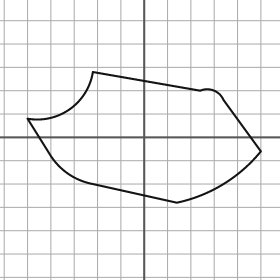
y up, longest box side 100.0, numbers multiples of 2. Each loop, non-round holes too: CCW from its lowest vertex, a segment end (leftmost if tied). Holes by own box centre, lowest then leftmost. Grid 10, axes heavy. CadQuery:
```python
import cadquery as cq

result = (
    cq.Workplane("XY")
    .moveTo(14.0, -28.0)
    .threePointArc((34.0, -20.0), (50.0, -6.0))
    .lineTo(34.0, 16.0)
    .threePointArc((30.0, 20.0), (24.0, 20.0))
    .lineTo(-22.0, 28.0)
    .threePointArc((-32.0, 12.0), (-50.0, 8.0))
    .lineTo(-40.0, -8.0)
    .threePointArc((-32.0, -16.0), (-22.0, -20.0))
    .close()
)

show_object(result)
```